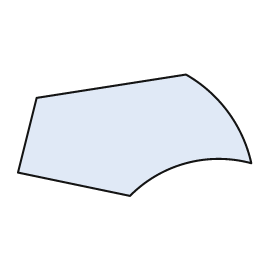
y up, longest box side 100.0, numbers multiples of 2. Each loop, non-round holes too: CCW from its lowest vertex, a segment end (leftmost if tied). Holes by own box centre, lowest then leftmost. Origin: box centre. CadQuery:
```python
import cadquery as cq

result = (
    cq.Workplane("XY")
    .moveTo(-2.0, -26.0)
    .threePointArc((22.0, -12.0), (50.0, -12.0))
    .threePointArc((40.0, 10.0), (22.0, 26.0))
    .lineTo(-42.0, 16.0)
    .lineTo(-50.0, -16.0)
    .close()
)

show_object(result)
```